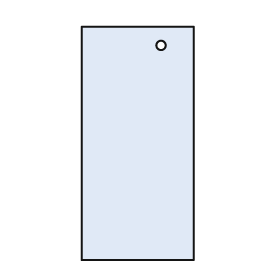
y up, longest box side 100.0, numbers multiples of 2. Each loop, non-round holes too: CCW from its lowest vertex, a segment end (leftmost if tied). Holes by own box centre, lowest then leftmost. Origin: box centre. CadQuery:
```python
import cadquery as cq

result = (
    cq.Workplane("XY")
    .moveTo(-24.0, -50.0)
    .lineTo(24.0, -50.0)
    .lineTo(24.0, 50.0)
    .lineTo(-24.0, 50.0)
    .close()
    .moveTo(10.0, 42.0)
    .circle(2.0)
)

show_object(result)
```